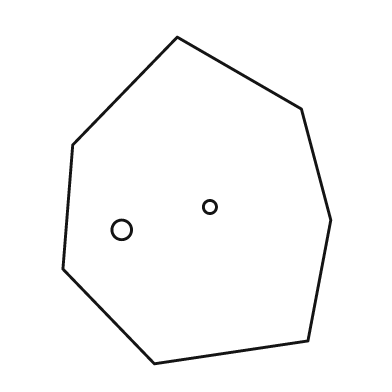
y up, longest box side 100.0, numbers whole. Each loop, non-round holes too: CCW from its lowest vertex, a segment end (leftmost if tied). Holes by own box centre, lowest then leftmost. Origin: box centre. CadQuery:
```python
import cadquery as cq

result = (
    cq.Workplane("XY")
    .moveTo(-13.0, -50.0)
    .lineTo(34.0, -43.0)
    .lineTo(41.0, -6.0)
    .lineTo(32.0, 28.0)
    .lineTo(-6.0, 50.0)
    .lineTo(-38.0, 17.0)
    .lineTo(-41.0, -21.0)
    .close()
    .moveTo(-23.0, -9.0)
    .circle(3.0)
    .moveTo(4.0, -2.0)
    .circle(2.0)
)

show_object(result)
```